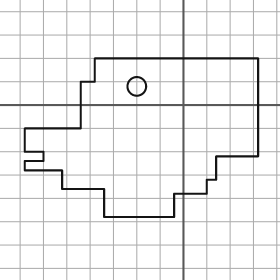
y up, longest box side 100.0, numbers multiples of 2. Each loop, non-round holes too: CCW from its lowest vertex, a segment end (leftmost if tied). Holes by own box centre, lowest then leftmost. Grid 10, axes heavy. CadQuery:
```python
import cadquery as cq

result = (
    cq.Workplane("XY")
    .moveTo(-34.0, -48.0)
    .lineTo(-4.0, -48.0)
    .lineTo(-4.0, -38.0)
    .lineTo(10.0, -38.0)
    .lineTo(10.0, -32.0)
    .lineTo(14.0, -32.0)
    .lineTo(14.0, -22.0)
    .lineTo(32.0, -22.0)
    .lineTo(32.0, 20.0)
    .lineTo(-38.0, 20.0)
    .lineTo(-38.0, 10.0)
    .lineTo(-44.0, 10.0)
    .lineTo(-44.0, -10.0)
    .lineTo(-68.0, -10.0)
    .lineTo(-68.0, -20.0)
    .lineTo(-60.0, -20.0)
    .lineTo(-60.0, -24.0)
    .lineTo(-68.0, -24.0)
    .lineTo(-68.0, -28.0)
    .lineTo(-52.0, -28.0)
    .lineTo(-52.0, -36.0)
    .lineTo(-34.0, -36.0)
    .close()
    .moveTo(-20.0, 8.0)
    .circle(4.0)
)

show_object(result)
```